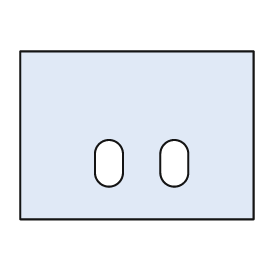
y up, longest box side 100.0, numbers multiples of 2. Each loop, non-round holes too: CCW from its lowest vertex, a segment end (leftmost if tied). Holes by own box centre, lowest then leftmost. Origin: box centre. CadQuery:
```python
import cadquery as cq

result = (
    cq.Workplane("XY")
    .moveTo(-50.0, -36.0)
    .lineTo(50.0, -36.0)
    .lineTo(50.0, 36.0)
    .lineTo(-50.0, 36.0)
    .close()
    .moveTo(-18.0, -16.0)
    .threePointArc((-12.0, -22.0), (-6.0, -16.0))
    .lineTo(-6.0, -8.0)
    .threePointArc((-12.0, -2.0), (-18.0, -8.0))
    .close()
    .moveTo(10.0, -16.0)
    .threePointArc((16.0, -22.0), (22.0, -16.0))
    .lineTo(22.0, -8.0)
    .threePointArc((16.0, -2.0), (10.0, -8.0))
    .close()
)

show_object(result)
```